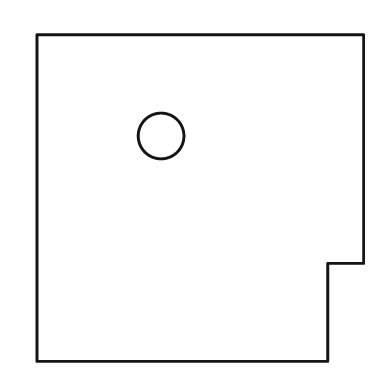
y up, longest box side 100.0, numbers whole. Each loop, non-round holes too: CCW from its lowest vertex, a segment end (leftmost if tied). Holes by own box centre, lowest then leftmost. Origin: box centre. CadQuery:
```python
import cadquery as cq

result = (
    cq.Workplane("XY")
    .moveTo(-50.0, -50.0)
    .lineTo(39.0, -50.0)
    .lineTo(39.0, -20.0)
    .lineTo(50.0, -20.0)
    .lineTo(50.0, 50.0)
    .lineTo(-50.0, 50.0)
    .close()
    .moveTo(-12.0, 19.0)
    .circle(7.0)
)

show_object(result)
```